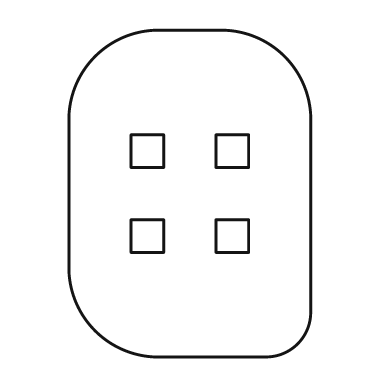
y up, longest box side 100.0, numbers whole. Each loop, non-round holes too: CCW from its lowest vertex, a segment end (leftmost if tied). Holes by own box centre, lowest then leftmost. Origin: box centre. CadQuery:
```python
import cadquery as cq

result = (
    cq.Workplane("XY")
    .moveTo(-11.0, -50.0)
    .lineTo(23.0, -50.0)
    .threePointArc((33.0, -46.0), (37.0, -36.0))
    .lineTo(37.0, 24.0)
    .threePointArc((29.0, 42.0), (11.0, 50.0))
    .lineTo(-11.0, 50.0)
    .threePointArc((-29.0, 42.0), (-37.0, 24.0))
    .lineTo(-37.0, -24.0)
    .threePointArc((-29.0, -42.0), (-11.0, -50.0))
    .close()
    .moveTo(-18.0, -18.0)
    .lineTo(-8.0, -18.0)
    .lineTo(-8.0, -8.0)
    .lineTo(-18.0, -8.0)
    .close()
    .moveTo(8.0, -18.0)
    .lineTo(18.0, -18.0)
    .lineTo(18.0, -8.0)
    .lineTo(8.0, -8.0)
    .close()
    .moveTo(-18.0, 8.0)
    .lineTo(-8.0, 8.0)
    .lineTo(-8.0, 18.0)
    .lineTo(-18.0, 18.0)
    .close()
    .moveTo(8.0, 8.0)
    .lineTo(18.0, 8.0)
    .lineTo(18.0, 18.0)
    .lineTo(8.0, 18.0)
    .close()
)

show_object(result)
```